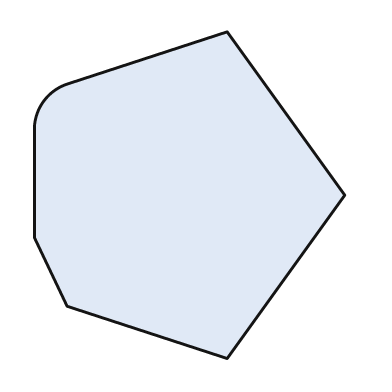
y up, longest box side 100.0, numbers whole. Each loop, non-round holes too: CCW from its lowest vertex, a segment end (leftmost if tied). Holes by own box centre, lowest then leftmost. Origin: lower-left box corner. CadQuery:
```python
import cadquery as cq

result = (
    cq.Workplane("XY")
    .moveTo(59.0, 0.0)
    .lineTo(95.0, 50.0)
    .lineTo(59.0, 100.0)
    .lineTo(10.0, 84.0)
    .threePointArc((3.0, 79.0), (0.0, 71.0))
    .lineTo(0.0, 37.0)
    .lineTo(10.0, 16.0)
    .close()
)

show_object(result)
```